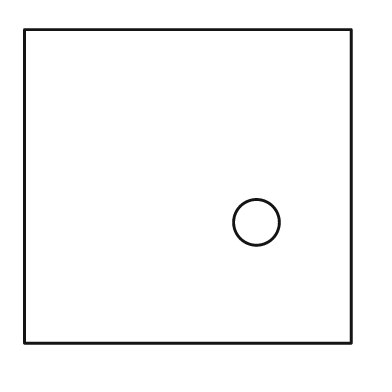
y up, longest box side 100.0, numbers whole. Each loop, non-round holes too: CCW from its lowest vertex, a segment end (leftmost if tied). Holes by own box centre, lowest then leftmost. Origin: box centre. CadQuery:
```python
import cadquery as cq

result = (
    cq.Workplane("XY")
    .moveTo(-50.0, -48.0)
    .lineTo(50.0, -48.0)
    .lineTo(50.0, 48.0)
    .lineTo(-50.0, 48.0)
    .close()
    .moveTo(21.0, -11.0)
    .circle(7.0)
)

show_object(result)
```